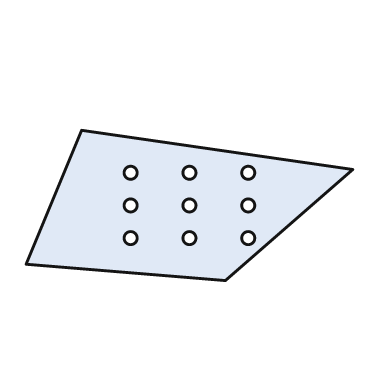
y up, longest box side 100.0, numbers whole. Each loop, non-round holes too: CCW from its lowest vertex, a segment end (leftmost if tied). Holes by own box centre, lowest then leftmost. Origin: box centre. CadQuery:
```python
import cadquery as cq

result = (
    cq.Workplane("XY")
    .moveTo(11.0, -23.0)
    .lineTo(50.0, 11.0)
    .lineTo(-33.0, 23.0)
    .lineTo(-50.0, -18.0)
    .close()
    .moveTo(-18.0, -10.0)
    .circle(2.0)
    .moveTo(0.0, -10.0)
    .circle(2.0)
    .moveTo(18.0, -10.0)
    .circle(2.0)
    .moveTo(-18.0, 0.0)
    .circle(2.0)
    .moveTo(0.0, 0.0)
    .circle(2.0)
    .moveTo(18.0, 0.0)
    .circle(2.0)
    .moveTo(-18.0, 10.0)
    .circle(2.0)
    .moveTo(0.0, 10.0)
    .circle(2.0)
    .moveTo(18.0, 10.0)
    .circle(2.0)
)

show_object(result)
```